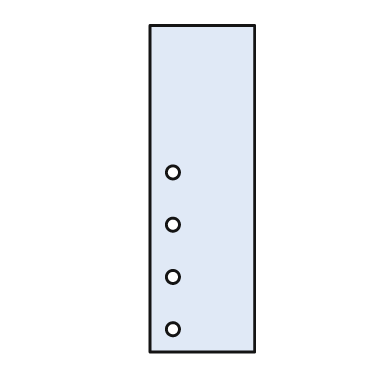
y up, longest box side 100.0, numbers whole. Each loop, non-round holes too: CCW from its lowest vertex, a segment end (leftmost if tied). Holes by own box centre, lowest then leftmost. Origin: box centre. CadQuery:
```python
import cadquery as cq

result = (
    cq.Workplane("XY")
    .moveTo(-16.0, -50.0)
    .lineTo(16.0, -50.0)
    .lineTo(16.0, 50.0)
    .lineTo(-16.0, 50.0)
    .close()
    .moveTo(-9.0, -43.0)
    .circle(2.0)
    .moveTo(-9.0, -27.0)
    .circle(2.0)
    .moveTo(-9.0, -11.0)
    .circle(2.0)
    .moveTo(-9.0, 5.0)
    .circle(2.0)
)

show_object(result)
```